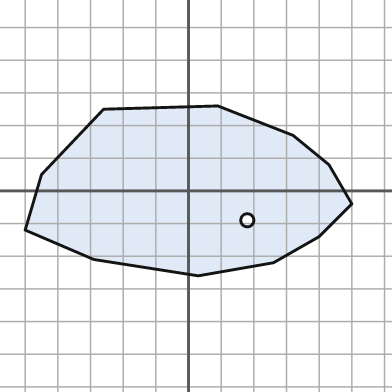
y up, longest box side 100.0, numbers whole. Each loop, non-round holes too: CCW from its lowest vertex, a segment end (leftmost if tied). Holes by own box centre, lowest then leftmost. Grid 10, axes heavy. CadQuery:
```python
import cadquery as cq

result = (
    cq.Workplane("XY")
    .moveTo(3.0, -26.0)
    .lineTo(26.0, -22.0)
    .lineTo(40.0, -14.0)
    .lineTo(50.0, -4.0)
    .lineTo(43.0, 8.0)
    .lineTo(32.0, 17.0)
    .lineTo(9.0, 26.0)
    .lineTo(-26.0, 25.0)
    .lineTo(-45.0, 5.0)
    .lineTo(-50.0, -12.0)
    .lineTo(-29.0, -21.0)
    .close()
    .moveTo(18.0, -9.0)
    .circle(2.0)
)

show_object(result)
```